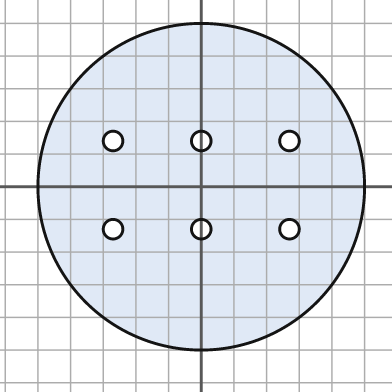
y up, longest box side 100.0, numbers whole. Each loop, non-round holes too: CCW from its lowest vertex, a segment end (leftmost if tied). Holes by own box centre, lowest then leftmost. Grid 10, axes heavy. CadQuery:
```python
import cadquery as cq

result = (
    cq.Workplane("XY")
    .moveTo(0.0, 0.0)
    .circle(50.0)
    .moveTo(-27.0, -13.0)
    .circle(3.0)
    .moveTo(0.0, -13.0)
    .circle(3.0)
    .moveTo(27.0, -13.0)
    .circle(3.0)
    .moveTo(-27.0, 14.0)
    .circle(3.0)
    .moveTo(0.0, 14.0)
    .circle(3.0)
    .moveTo(27.0, 14.0)
    .circle(3.0)
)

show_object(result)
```